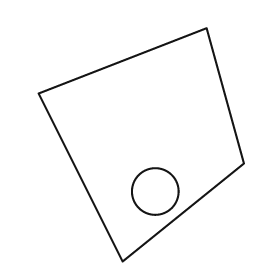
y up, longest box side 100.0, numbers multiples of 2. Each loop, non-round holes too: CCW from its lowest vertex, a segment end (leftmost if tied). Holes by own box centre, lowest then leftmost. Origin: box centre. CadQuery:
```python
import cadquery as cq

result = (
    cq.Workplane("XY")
    .moveTo(-8.0, -50.0)
    .lineTo(44.0, -8.0)
    .lineTo(28.0, 50.0)
    .lineTo(-44.0, 22.0)
    .close()
    .moveTo(6.0, -20.0)
    .circle(10.0)
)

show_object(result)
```